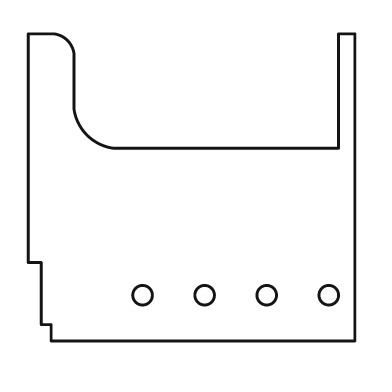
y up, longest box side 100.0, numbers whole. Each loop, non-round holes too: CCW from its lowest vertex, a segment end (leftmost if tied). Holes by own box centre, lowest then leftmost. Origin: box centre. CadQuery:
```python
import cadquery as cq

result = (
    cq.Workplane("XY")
    .moveTo(-43.0, -47.0)
    .lineTo(50.0, -47.0)
    .lineTo(50.0, 47.0)
    .lineTo(45.0, 47.0)
    .lineTo(45.0, 12.0)
    .lineTo(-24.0, 12.0)
    .threePointArc((-32.0, 16.0), (-36.0, 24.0))
    .lineTo(-36.0, 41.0)
    .threePointArc((-38.0, 45.0), (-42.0, 47.0))
    .lineTo(-50.0, 47.0)
    .lineTo(-50.0, -23.0)
    .lineTo(-46.0, -23.0)
    .lineTo(-46.0, -42.0)
    .lineTo(-43.0, -42.0)
    .close()
    .moveTo(-15.0, -33.0)
    .circle(3.0)
    .moveTo(4.0, -33.0)
    .circle(3.0)
    .moveTo(23.0, -33.0)
    .circle(3.0)
    .moveTo(42.0, -33.0)
    .circle(3.0)
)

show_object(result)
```